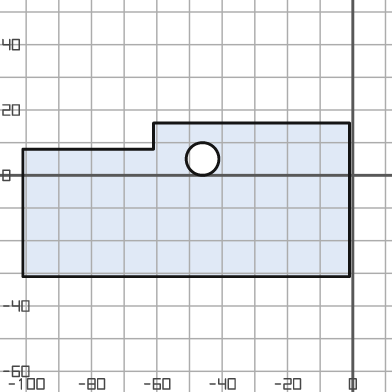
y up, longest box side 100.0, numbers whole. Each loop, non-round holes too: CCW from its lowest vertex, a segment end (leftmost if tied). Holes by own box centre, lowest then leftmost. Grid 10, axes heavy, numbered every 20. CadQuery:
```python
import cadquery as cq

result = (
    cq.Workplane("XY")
    .moveTo(-101.0, -31.0)
    .lineTo(-1.0, -31.0)
    .lineTo(-1.0, 16.0)
    .lineTo(-61.0, 16.0)
    .lineTo(-61.0, 8.0)
    .lineTo(-101.0, 8.0)
    .close()
    .moveTo(-46.0, 5.0)
    .circle(5.0)
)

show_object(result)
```